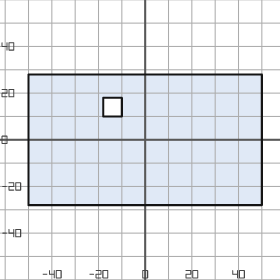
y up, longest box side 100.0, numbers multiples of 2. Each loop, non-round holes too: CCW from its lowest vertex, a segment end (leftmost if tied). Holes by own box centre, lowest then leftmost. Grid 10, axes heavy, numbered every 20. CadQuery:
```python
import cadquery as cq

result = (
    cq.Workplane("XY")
    .moveTo(-50.0, -28.0)
    .lineTo(50.0, -28.0)
    .lineTo(50.0, 28.0)
    .lineTo(-50.0, 28.0)
    .close()
    .moveTo(-18.0, 10.0)
    .lineTo(-10.0, 10.0)
    .lineTo(-10.0, 18.0)
    .lineTo(-18.0, 18.0)
    .close()
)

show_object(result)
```